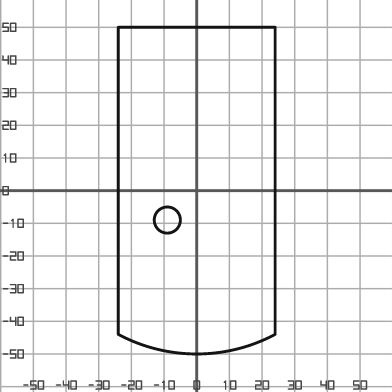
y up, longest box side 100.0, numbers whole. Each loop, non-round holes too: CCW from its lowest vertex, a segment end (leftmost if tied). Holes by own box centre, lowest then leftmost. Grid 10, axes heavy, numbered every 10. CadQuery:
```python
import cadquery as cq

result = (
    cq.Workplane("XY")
    .moveTo(-24.0, -44.0)
    .threePointArc((0.0, -50.0), (24.0, -44.0))
    .lineTo(24.0, 50.0)
    .lineTo(-24.0, 50.0)
    .close()
    .moveTo(-9.0, -9.0)
    .circle(4.0)
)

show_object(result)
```